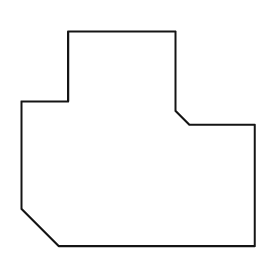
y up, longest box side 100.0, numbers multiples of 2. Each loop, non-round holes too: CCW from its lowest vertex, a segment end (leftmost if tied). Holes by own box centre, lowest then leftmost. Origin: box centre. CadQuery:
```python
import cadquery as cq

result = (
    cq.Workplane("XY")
    .moveTo(-34.0, -46.0)
    .lineTo(50.0, -46.0)
    .lineTo(50.0, 6.0)
    .lineTo(22.0, 6.0)
    .lineTo(16.0, 12.0)
    .lineTo(16.0, 46.0)
    .lineTo(-30.0, 46.0)
    .lineTo(-30.0, 16.0)
    .lineTo(-50.0, 16.0)
    .lineTo(-50.0, -30.0)
    .close()
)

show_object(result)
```